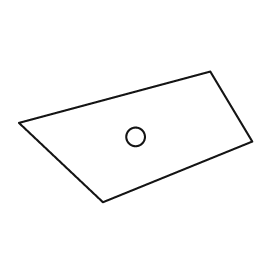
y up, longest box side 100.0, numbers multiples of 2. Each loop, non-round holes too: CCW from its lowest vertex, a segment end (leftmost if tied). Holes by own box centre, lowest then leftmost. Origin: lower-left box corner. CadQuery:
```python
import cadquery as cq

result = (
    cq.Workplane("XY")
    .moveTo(36.0, 0.0)
    .lineTo(100.0, 26.0)
    .lineTo(82.0, 56.0)
    .lineTo(0.0, 34.0)
    .close()
    .moveTo(50.0, 28.0)
    .circle(4.0)
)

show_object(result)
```